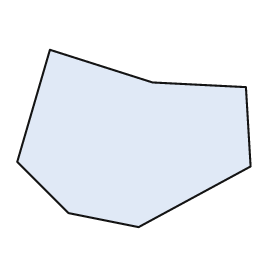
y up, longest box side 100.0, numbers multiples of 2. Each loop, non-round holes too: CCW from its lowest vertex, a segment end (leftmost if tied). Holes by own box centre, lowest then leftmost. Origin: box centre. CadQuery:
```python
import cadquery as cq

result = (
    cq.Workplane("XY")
    .moveTo(2.0, -38.0)
    .lineTo(50.0, -12.0)
    .lineTo(48.0, 22.0)
    .lineTo(8.0, 24.0)
    .lineTo(-36.0, 38.0)
    .lineTo(-50.0, -10.0)
    .lineTo(-28.0, -32.0)
    .close()
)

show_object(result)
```